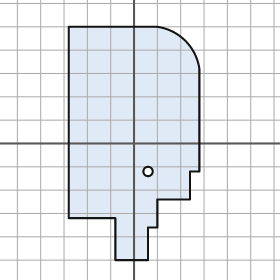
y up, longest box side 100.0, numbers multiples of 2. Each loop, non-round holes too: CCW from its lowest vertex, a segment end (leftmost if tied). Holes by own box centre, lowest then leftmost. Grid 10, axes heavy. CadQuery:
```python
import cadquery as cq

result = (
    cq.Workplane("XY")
    .moveTo(-8.0, -50.0)
    .lineTo(6.0, -50.0)
    .lineTo(6.0, -36.0)
    .lineTo(10.0, -36.0)
    .lineTo(10.0, -24.0)
    .lineTo(24.0, -24.0)
    .lineTo(24.0, -12.0)
    .lineTo(28.0, -12.0)
    .lineTo(28.0, 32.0)
    .threePointArc((22.0, 44.0), (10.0, 50.0))
    .lineTo(-28.0, 50.0)
    .lineTo(-28.0, -32.0)
    .lineTo(-8.0, -32.0)
    .close()
    .moveTo(6.0, -12.0)
    .circle(2.0)
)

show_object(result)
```